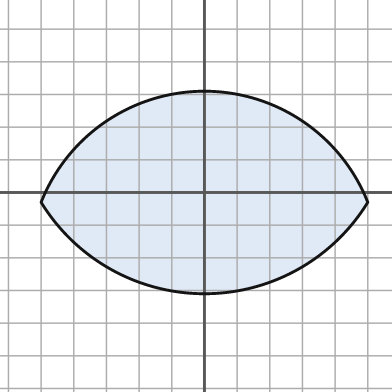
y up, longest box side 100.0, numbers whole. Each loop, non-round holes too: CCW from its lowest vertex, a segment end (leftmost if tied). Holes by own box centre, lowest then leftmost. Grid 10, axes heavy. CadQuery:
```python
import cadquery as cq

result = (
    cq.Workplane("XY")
    .moveTo(-50.0, -3.0)
    .threePointArc((0.0, -31.0), (50.0, -3.0))
    .threePointArc((0.0, 31.0), (-50.0, -3.0))
    .close()
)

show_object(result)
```